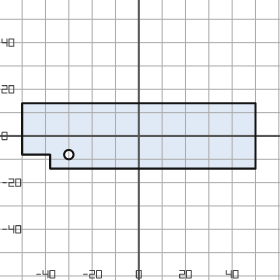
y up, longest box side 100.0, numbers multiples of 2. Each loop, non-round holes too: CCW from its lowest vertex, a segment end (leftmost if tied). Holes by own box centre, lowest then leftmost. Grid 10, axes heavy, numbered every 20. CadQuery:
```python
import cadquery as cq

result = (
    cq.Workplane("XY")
    .moveTo(-38.0, -14.0)
    .lineTo(50.0, -14.0)
    .lineTo(50.0, 14.0)
    .lineTo(-50.0, 14.0)
    .lineTo(-50.0, -8.0)
    .lineTo(-38.0, -8.0)
    .close()
    .moveTo(-30.0, -8.0)
    .circle(2.0)
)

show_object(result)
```